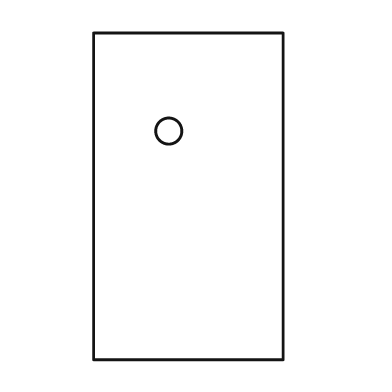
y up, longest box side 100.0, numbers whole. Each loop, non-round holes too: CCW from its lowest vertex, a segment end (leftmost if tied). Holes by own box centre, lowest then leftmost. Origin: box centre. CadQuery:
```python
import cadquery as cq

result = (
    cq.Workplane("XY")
    .moveTo(-29.0, -50.0)
    .lineTo(29.0, -50.0)
    .lineTo(29.0, 50.0)
    .lineTo(-29.0, 50.0)
    .close()
    .moveTo(-6.0, 20.0)
    .circle(4.0)
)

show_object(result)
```